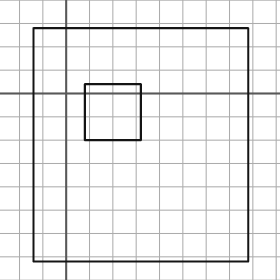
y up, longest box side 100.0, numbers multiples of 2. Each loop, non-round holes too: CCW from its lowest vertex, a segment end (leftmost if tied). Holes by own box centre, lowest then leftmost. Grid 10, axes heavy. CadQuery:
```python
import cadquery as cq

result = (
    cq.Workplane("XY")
    .moveTo(-14.0, -72.0)
    .lineTo(78.0, -72.0)
    .lineTo(78.0, 28.0)
    .lineTo(-14.0, 28.0)
    .close()
    .moveTo(8.0, -20.0)
    .lineTo(32.0, -20.0)
    .lineTo(32.0, 4.0)
    .lineTo(8.0, 4.0)
    .close()
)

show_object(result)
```